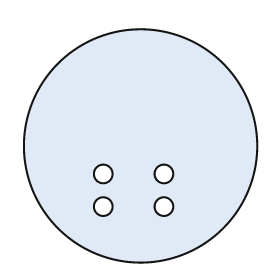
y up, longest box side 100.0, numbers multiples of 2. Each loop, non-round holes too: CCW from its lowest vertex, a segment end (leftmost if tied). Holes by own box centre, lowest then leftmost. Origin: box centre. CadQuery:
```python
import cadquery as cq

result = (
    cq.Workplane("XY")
    .moveTo(0.0, 0.0)
    .circle(50.0)
    .moveTo(-16.0, -26.0)
    .circle(4.0)
    .moveTo(10.0, -26.0)
    .circle(4.0)
    .moveTo(-16.0, -12.0)
    .circle(4.0)
    .moveTo(10.0, -12.0)
    .circle(4.0)
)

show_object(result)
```